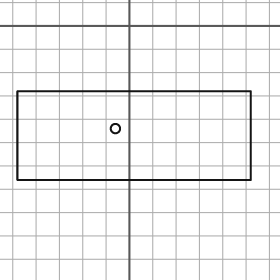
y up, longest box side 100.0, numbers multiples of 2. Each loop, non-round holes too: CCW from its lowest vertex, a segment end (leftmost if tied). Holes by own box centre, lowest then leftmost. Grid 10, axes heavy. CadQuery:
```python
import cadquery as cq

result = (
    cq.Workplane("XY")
    .moveTo(-48.0, -66.0)
    .lineTo(52.0, -66.0)
    .lineTo(52.0, -28.0)
    .lineTo(-48.0, -28.0)
    .close()
    .moveTo(-6.0, -44.0)
    .circle(2.0)
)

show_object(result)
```